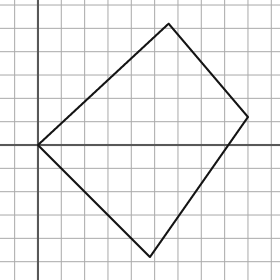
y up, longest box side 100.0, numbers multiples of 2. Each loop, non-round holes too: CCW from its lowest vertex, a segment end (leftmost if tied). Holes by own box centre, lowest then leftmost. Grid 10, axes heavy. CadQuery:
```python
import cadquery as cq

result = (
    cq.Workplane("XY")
    .moveTo(48.0, -48.0)
    .lineTo(90.0, 12.0)
    .lineTo(56.0, 52.0)
    .lineTo(0.0, 0.0)
    .close()
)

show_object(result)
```